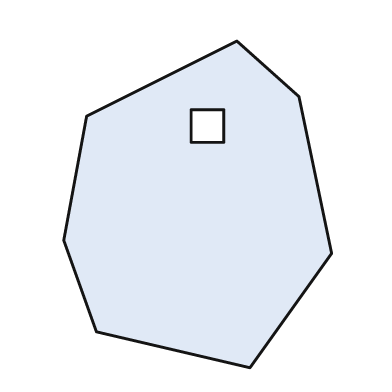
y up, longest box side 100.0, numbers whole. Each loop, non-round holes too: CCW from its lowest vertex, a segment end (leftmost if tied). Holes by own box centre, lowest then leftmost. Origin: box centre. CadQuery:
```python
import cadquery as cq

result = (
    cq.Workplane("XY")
    .moveTo(16.0, -50.0)
    .lineTo(41.0, -15.0)
    .lineTo(31.0, 33.0)
    .lineTo(12.0, 50.0)
    .lineTo(-34.0, 27.0)
    .lineTo(-41.0, -11.0)
    .lineTo(-31.0, -39.0)
    .close()
    .moveTo(-2.0, 19.0)
    .lineTo(8.0, 19.0)
    .lineTo(8.0, 29.0)
    .lineTo(-2.0, 29.0)
    .close()
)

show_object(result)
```